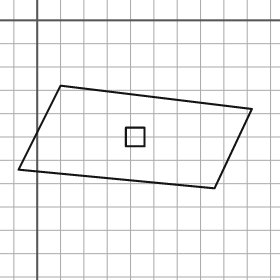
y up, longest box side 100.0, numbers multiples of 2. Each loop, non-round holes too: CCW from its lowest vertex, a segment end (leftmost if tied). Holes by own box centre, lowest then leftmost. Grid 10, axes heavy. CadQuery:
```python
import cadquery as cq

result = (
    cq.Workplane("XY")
    .moveTo(76.0, -72.0)
    .lineTo(92.0, -38.0)
    .lineTo(10.0, -28.0)
    .lineTo(-8.0, -64.0)
    .close()
    .moveTo(38.0, -54.0)
    .lineTo(46.0, -54.0)
    .lineTo(46.0, -46.0)
    .lineTo(38.0, -46.0)
    .close()
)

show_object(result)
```